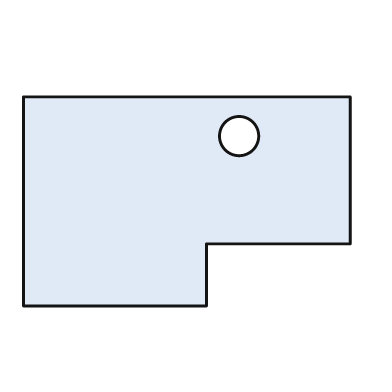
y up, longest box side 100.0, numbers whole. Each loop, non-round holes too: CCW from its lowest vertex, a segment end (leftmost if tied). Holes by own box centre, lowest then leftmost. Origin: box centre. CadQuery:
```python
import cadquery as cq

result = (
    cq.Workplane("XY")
    .moveTo(-50.0, -32.0)
    .lineTo(6.0, -32.0)
    .lineTo(6.0, -13.0)
    .lineTo(50.0, -13.0)
    .lineTo(50.0, 32.0)
    .lineTo(-50.0, 32.0)
    .close()
    .moveTo(16.0, 20.0)
    .circle(6.0)
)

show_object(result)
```